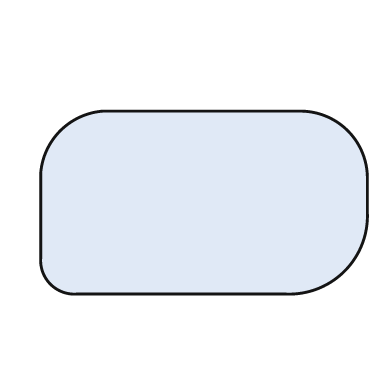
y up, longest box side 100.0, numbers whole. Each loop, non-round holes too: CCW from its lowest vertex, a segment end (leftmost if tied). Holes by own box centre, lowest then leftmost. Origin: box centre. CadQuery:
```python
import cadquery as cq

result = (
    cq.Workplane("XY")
    .moveTo(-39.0, -28.0)
    .lineTo(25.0, -28.0)
    .threePointArc((43.0, -21.0), (50.0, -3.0))
    .lineTo(50.0, 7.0)
    .threePointArc((44.0, 22.0), (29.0, 28.0))
    .lineTo(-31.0, 28.0)
    .threePointArc((-44.0, 22.0), (-50.0, 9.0))
    .lineTo(-50.0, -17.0)
    .threePointArc((-47.0, -25.0), (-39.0, -28.0))
    .close()
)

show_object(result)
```